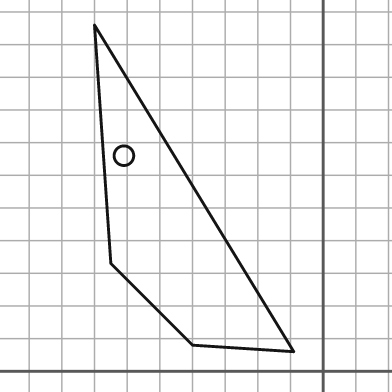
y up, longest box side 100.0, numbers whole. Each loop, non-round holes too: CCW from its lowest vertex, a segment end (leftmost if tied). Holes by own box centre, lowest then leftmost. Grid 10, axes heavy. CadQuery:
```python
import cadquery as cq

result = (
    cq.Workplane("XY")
    .moveTo(-9.0, 6.0)
    .lineTo(-70.0, 106.0)
    .lineTo(-65.0, 33.0)
    .lineTo(-40.0, 8.0)
    .close()
    .moveTo(-61.0, 66.0)
    .circle(3.0)
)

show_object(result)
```